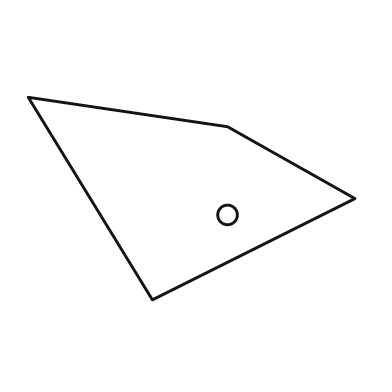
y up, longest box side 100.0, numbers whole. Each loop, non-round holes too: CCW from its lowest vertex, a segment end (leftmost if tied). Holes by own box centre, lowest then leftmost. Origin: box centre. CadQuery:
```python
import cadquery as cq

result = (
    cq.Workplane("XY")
    .moveTo(-12.0, -31.0)
    .lineTo(50.0, 0.0)
    .lineTo(11.0, 22.0)
    .lineTo(-50.0, 31.0)
    .close()
    .moveTo(11.0, -5.0)
    .circle(3.0)
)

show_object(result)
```